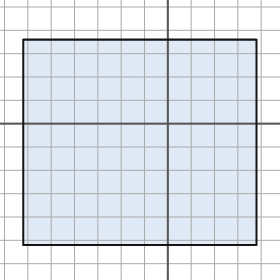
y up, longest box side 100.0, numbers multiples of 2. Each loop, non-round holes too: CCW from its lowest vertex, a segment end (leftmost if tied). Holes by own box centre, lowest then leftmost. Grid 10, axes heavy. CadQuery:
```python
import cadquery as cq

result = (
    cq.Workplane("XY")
    .moveTo(-62.0, -52.0)
    .lineTo(38.0, -52.0)
    .lineTo(38.0, 36.0)
    .lineTo(-62.0, 36.0)
    .close()
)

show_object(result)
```